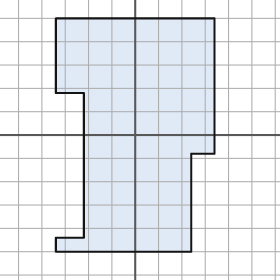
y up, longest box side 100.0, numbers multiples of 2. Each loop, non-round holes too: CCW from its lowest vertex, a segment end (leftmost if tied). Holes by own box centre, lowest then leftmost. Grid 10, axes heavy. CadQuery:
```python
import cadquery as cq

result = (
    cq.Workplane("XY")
    .moveTo(-34.0, -50.0)
    .lineTo(24.0, -50.0)
    .lineTo(24.0, -8.0)
    .lineTo(34.0, -8.0)
    .lineTo(34.0, 50.0)
    .lineTo(-34.0, 50.0)
    .lineTo(-34.0, 18.0)
    .lineTo(-22.0, 18.0)
    .lineTo(-22.0, -44.0)
    .lineTo(-34.0, -44.0)
    .close()
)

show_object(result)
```